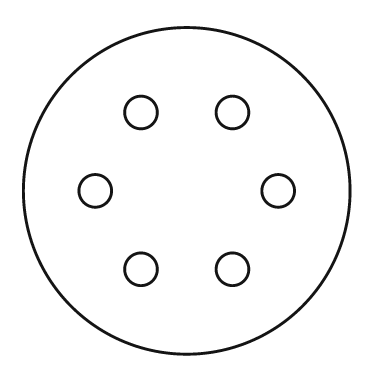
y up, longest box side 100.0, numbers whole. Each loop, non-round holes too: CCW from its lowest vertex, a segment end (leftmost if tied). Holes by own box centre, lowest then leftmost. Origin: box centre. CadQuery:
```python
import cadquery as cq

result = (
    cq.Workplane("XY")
    .moveTo(0.0, 0.0)
    .circle(50.0)
    .moveTo(-14.0, -24.0)
    .circle(5.0)
    .moveTo(14.0, -24.0)
    .circle(5.0)
    .moveTo(-28.0, 0.0)
    .circle(5.0)
    .moveTo(28.0, 0.0)
    .circle(5.0)
    .moveTo(-14.0, 24.0)
    .circle(5.0)
    .moveTo(14.0, 24.0)
    .circle(5.0)
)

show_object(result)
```